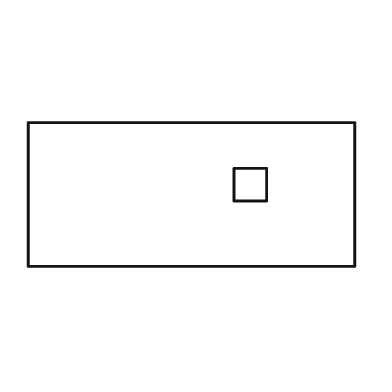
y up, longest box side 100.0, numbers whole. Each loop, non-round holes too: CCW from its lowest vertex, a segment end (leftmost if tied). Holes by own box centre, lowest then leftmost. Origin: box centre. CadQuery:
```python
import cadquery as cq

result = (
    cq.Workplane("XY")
    .moveTo(-50.0, -22.0)
    .lineTo(50.0, -22.0)
    .lineTo(50.0, 22.0)
    .lineTo(-50.0, 22.0)
    .close()
    .moveTo(13.0, -2.0)
    .lineTo(23.0, -2.0)
    .lineTo(23.0, 8.0)
    .lineTo(13.0, 8.0)
    .close()
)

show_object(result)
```